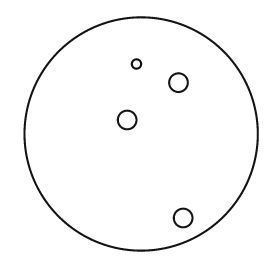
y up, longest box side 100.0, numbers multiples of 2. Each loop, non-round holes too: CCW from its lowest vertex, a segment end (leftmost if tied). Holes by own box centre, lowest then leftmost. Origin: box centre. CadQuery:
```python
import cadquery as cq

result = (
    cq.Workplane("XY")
    .moveTo(0.0, 0.0)
    .circle(50.0)
    .moveTo(18.0, -36.0)
    .circle(4.0)
    .moveTo(-6.0, 6.0)
    .circle(4.0)
    .moveTo(16.0, 22.0)
    .circle(4.0)
    .moveTo(-2.0, 30.0)
    .circle(2.0)
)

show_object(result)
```